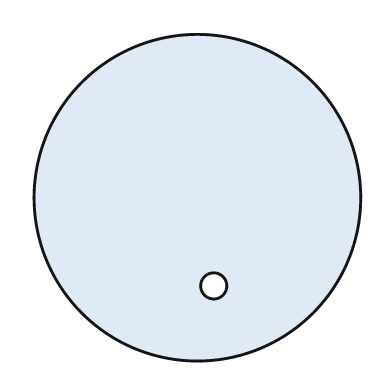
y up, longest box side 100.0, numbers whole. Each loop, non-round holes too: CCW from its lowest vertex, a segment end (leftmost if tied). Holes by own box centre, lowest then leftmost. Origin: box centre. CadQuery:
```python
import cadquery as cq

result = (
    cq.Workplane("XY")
    .moveTo(0.0, 0.0)
    .circle(50.0)
    .moveTo(5.0, -27.0)
    .circle(4.0)
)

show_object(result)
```